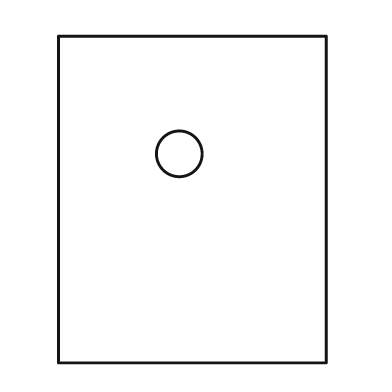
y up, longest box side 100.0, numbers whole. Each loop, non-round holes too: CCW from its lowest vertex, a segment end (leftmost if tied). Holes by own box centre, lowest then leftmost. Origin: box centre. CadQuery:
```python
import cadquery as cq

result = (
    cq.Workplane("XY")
    .moveTo(-41.0, -50.0)
    .lineTo(41.0, -50.0)
    .lineTo(41.0, 50.0)
    .lineTo(-41.0, 50.0)
    .close()
    .moveTo(-4.0, 14.0)
    .circle(7.0)
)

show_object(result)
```